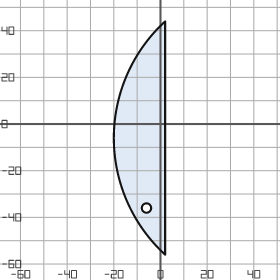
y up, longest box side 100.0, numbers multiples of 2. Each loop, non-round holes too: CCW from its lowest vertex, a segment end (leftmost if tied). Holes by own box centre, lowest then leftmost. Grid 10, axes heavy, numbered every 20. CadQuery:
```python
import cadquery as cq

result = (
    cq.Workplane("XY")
    .moveTo(2.0, -56.0)
    .lineTo(2.0, 44.0)
    .threePointArc((-20.0, -6.0), (2.0, -56.0))
    .close()
    .moveTo(-6.0, -36.0)
    .circle(2.0)
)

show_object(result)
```